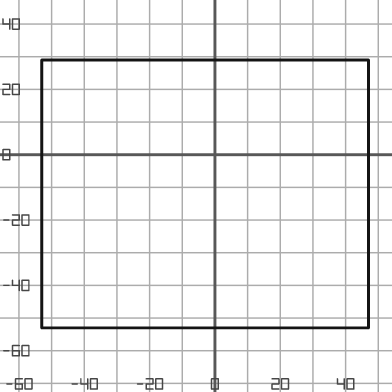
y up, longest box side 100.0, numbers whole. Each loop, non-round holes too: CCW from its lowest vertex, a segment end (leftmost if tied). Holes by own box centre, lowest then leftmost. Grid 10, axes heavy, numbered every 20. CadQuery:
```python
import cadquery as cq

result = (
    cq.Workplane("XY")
    .moveTo(-53.0, -53.0)
    .lineTo(47.0, -53.0)
    .lineTo(47.0, 29.0)
    .lineTo(-53.0, 29.0)
    .close()
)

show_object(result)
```